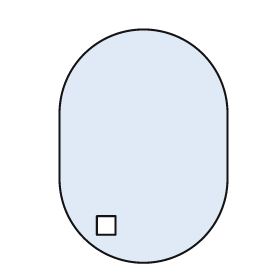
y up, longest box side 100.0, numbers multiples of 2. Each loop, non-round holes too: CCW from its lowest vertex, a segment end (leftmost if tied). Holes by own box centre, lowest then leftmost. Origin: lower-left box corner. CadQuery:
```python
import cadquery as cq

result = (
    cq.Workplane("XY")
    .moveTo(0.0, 36.0)
    .threePointArc((36.0, 0.0), (72.0, 36.0))
    .lineTo(72.0, 64.0)
    .threePointArc((36.0, 100.0), (0.0, 64.0))
    .close()
    .moveTo(16.0, 12.0)
    .lineTo(24.0, 12.0)
    .lineTo(24.0, 20.0)
    .lineTo(16.0, 20.0)
    .close()
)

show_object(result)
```